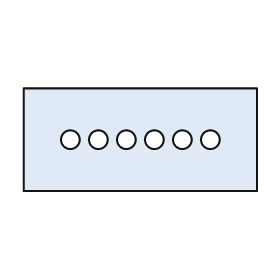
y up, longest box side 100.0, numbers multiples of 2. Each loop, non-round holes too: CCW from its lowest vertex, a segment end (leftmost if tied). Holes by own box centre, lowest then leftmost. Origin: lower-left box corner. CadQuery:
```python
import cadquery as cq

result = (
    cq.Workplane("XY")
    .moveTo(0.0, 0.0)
    .lineTo(100.0, 0.0)
    .lineTo(100.0, 44.0)
    .lineTo(0.0, 44.0)
    .close()
    .moveTo(20.0, 22.0)
    .circle(4.0)
    .moveTo(32.0, 22.0)
    .circle(4.0)
    .moveTo(44.0, 22.0)
    .circle(4.0)
    .moveTo(56.0, 22.0)
    .circle(4.0)
    .moveTo(68.0, 22.0)
    .circle(4.0)
    .moveTo(80.0, 22.0)
    .circle(4.0)
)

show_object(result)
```